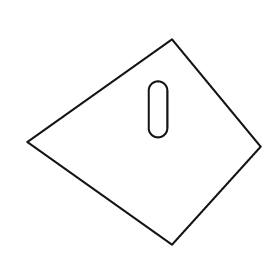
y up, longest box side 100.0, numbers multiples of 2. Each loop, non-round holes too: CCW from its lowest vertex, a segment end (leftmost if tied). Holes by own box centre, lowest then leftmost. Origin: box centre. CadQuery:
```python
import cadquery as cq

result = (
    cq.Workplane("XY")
    .moveTo(12.0, -44.0)
    .lineTo(50.0, -2.0)
    .lineTo(12.0, 44.0)
    .lineTo(-50.0, 0.0)
    .close()
    .moveTo(2.0, 6.0)
    .threePointArc((6.0, 2.0), (10.0, 6.0))
    .lineTo(10.0, 22.0)
    .threePointArc((6.0, 26.0), (2.0, 22.0))
    .close()
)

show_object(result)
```